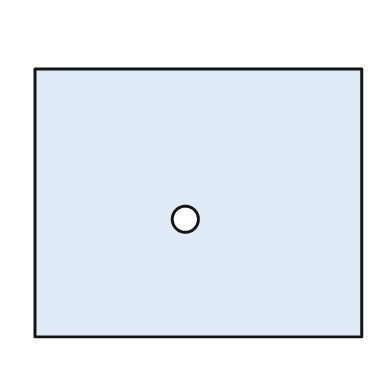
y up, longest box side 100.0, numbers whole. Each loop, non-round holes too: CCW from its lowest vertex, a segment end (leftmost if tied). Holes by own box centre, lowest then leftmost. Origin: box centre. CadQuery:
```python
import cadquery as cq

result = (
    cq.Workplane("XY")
    .moveTo(-50.0, -41.0)
    .lineTo(50.0, -41.0)
    .lineTo(50.0, 41.0)
    .lineTo(-50.0, 41.0)
    .close()
    .moveTo(-4.0, -5.0)
    .circle(4.0)
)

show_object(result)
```